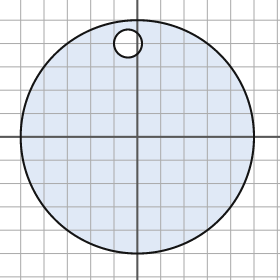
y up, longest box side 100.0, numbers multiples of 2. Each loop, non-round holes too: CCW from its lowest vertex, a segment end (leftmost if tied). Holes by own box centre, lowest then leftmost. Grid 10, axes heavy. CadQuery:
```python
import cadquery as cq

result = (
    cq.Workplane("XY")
    .moveTo(0.0, 0.0)
    .circle(50.0)
    .moveTo(-4.0, 40.0)
    .circle(6.0)
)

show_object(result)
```